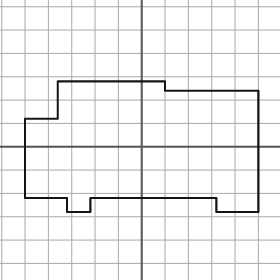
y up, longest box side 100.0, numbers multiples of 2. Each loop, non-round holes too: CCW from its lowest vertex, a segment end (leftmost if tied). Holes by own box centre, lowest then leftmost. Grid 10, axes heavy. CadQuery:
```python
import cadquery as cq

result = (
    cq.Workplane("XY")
    .moveTo(-32.0, -28.0)
    .lineTo(-22.0, -28.0)
    .lineTo(-22.0, -22.0)
    .lineTo(32.0, -22.0)
    .lineTo(32.0, -28.0)
    .lineTo(50.0, -28.0)
    .lineTo(50.0, 24.0)
    .lineTo(10.0, 24.0)
    .lineTo(10.0, 28.0)
    .lineTo(-36.0, 28.0)
    .lineTo(-36.0, 12.0)
    .lineTo(-50.0, 12.0)
    .lineTo(-50.0, -22.0)
    .lineTo(-32.0, -22.0)
    .close()
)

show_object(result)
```